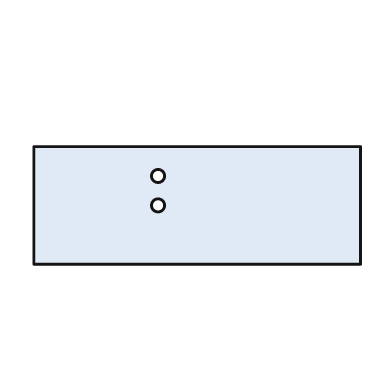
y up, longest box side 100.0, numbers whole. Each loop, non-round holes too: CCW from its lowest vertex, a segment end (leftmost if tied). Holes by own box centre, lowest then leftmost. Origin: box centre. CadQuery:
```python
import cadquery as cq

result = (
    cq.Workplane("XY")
    .moveTo(-50.0, -18.0)
    .lineTo(50.0, -18.0)
    .lineTo(50.0, 18.0)
    .lineTo(-50.0, 18.0)
    .close()
    .moveTo(-12.0, 0.0)
    .circle(2.0)
    .moveTo(-12.0, 9.0)
    .circle(2.0)
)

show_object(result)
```